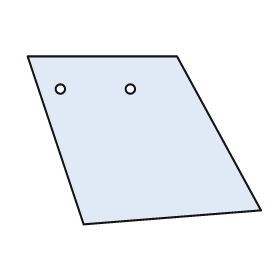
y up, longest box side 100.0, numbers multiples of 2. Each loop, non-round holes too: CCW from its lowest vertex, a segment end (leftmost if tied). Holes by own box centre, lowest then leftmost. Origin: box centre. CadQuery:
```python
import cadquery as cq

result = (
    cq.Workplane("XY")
    .moveTo(-26.0, -36.0)
    .lineTo(50.0, -30.0)
    .lineTo(14.0, 36.0)
    .lineTo(-50.0, 36.0)
    .close()
    .moveTo(-36.0, 22.0)
    .circle(2.0)
    .moveTo(-6.0, 22.0)
    .circle(2.0)
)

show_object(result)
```